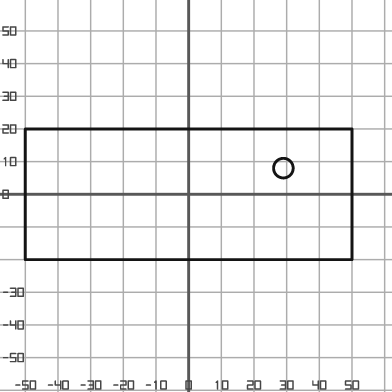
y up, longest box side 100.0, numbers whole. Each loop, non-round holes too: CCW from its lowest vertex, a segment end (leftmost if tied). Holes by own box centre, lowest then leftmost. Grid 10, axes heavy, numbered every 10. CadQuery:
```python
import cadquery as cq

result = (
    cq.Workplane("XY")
    .moveTo(-50.0, -20.0)
    .lineTo(50.0, -20.0)
    .lineTo(50.0, 20.0)
    .lineTo(-50.0, 20.0)
    .close()
    .moveTo(29.0, 8.0)
    .circle(3.0)
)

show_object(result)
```